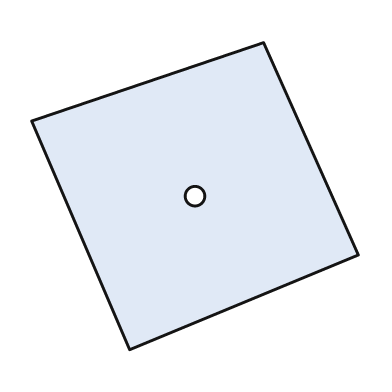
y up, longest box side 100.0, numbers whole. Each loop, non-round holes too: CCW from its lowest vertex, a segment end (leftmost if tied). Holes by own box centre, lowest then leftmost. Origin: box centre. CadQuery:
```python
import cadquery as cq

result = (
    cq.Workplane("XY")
    .moveTo(-20.0, -47.0)
    .lineTo(50.0, -18.0)
    .lineTo(21.0, 47.0)
    .lineTo(-50.0, 23.0)
    .close()
    .moveTo(0.0, 0.0)
    .circle(3.0)
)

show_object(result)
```